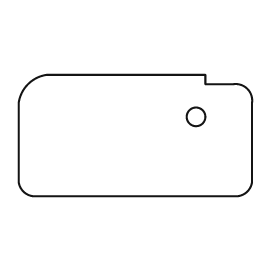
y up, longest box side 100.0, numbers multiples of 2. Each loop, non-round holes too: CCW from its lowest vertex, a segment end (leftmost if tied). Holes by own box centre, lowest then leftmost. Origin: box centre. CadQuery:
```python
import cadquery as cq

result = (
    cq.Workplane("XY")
    .moveTo(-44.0, -26.0)
    .lineTo(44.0, -26.0)
    .threePointArc((48.0, -24.0), (50.0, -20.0))
    .lineTo(50.0, 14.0)
    .threePointArc((48.0, 20.0), (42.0, 22.0))
    .lineTo(30.0, 22.0)
    .lineTo(30.0, 26.0)
    .lineTo(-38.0, 26.0)
    .threePointArc((-46.0, 22.0), (-50.0, 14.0))
    .lineTo(-50.0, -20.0)
    .threePointArc((-48.0, -24.0), (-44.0, -26.0))
    .close()
    .moveTo(26.0, 8.0)
    .circle(4.0)
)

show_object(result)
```